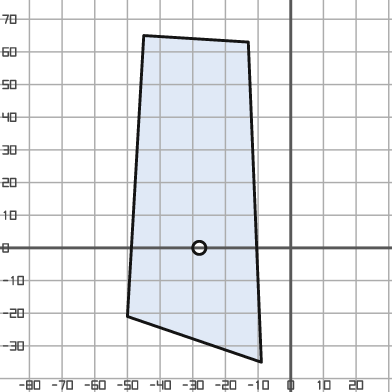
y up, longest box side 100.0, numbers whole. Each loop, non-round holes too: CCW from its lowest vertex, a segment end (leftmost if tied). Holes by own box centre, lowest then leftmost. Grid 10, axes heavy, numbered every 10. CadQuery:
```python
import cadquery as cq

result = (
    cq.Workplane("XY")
    .moveTo(-9.0, -35.0)
    .lineTo(-13.0, 63.0)
    .lineTo(-45.0, 65.0)
    .lineTo(-50.0, -21.0)
    .close()
    .moveTo(-28.0, 0.0)
    .circle(2.0)
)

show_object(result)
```